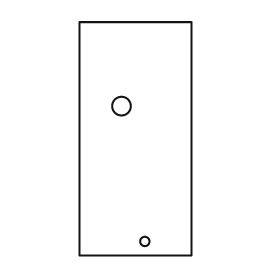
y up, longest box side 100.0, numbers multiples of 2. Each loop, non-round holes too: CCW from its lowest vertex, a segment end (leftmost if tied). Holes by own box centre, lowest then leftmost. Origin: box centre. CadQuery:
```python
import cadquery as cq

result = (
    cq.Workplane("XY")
    .moveTo(-24.0, -50.0)
    .lineTo(24.0, -50.0)
    .lineTo(24.0, 50.0)
    .lineTo(-24.0, 50.0)
    .close()
    .moveTo(4.0, -44.0)
    .circle(2.0)
    .moveTo(-6.0, 14.0)
    .circle(4.0)
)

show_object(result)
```